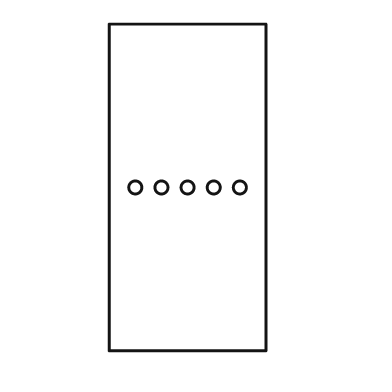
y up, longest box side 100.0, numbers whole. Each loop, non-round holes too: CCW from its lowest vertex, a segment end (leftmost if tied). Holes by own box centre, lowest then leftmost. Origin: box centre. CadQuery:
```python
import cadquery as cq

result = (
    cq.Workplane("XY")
    .moveTo(-24.0, -50.0)
    .lineTo(24.0, -50.0)
    .lineTo(24.0, 50.0)
    .lineTo(-24.0, 50.0)
    .close()
    .moveTo(-16.0, 0.0)
    .circle(2.0)
    .moveTo(-8.0, 0.0)
    .circle(2.0)
    .moveTo(0.0, 0.0)
    .circle(2.0)
    .moveTo(8.0, 0.0)
    .circle(2.0)
    .moveTo(16.0, 0.0)
    .circle(2.0)
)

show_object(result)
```